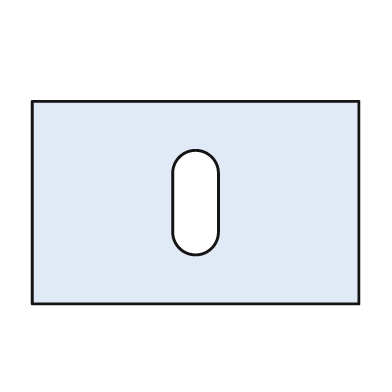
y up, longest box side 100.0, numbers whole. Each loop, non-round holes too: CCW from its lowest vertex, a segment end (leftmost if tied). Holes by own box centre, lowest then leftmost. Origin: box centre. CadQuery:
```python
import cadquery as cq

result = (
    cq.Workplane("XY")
    .moveTo(-50.0, -31.0)
    .lineTo(50.0, -31.0)
    .lineTo(50.0, 31.0)
    .lineTo(-50.0, 31.0)
    .close()
    .moveTo(-7.0, -9.0)
    .threePointArc((0.0, -16.0), (7.0, -9.0))
    .lineTo(7.0, 9.0)
    .threePointArc((0.0, 16.0), (-7.0, 9.0))
    .close()
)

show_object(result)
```